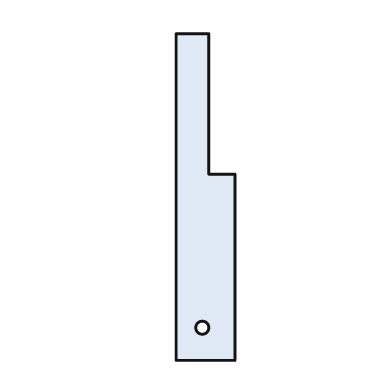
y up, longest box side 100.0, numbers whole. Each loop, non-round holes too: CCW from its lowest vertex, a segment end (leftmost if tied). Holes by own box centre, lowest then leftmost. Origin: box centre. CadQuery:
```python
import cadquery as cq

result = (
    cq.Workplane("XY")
    .moveTo(-9.0, -50.0)
    .lineTo(9.0, -50.0)
    .lineTo(9.0, 7.0)
    .lineTo(1.0, 7.0)
    .lineTo(1.0, 50.0)
    .lineTo(-9.0, 50.0)
    .close()
    .moveTo(-1.0, -40.0)
    .circle(2.0)
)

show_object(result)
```